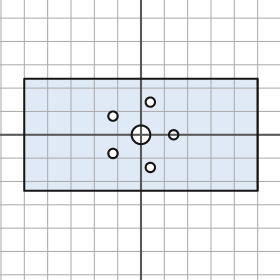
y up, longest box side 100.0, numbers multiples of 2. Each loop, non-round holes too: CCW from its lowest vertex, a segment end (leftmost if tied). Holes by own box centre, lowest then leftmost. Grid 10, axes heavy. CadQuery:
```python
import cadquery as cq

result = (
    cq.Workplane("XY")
    .moveTo(-50.0, -24.0)
    .lineTo(50.0, -24.0)
    .lineTo(50.0, 24.0)
    .lineTo(-50.0, 24.0)
    .close()
    .moveTo(4.0, -14.0)
    .circle(2.0)
    .moveTo(-12.0, -8.0)
    .circle(2.0)
    .moveTo(0.0, 0.0)
    .circle(4.0)
    .moveTo(14.0, 0.0)
    .circle(2.0)
    .moveTo(-12.0, 8.0)
    .circle(2.0)
    .moveTo(4.0, 14.0)
    .circle(2.0)
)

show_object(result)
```